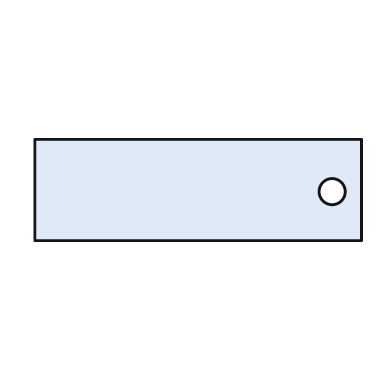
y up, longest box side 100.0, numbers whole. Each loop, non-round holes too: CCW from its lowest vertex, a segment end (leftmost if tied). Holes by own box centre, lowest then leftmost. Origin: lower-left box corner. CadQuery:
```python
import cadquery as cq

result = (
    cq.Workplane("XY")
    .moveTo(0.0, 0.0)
    .lineTo(100.0, 0.0)
    .lineTo(100.0, 31.0)
    .lineTo(0.0, 31.0)
    .close()
    .moveTo(91.0, 15.0)
    .circle(4.0)
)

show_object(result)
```